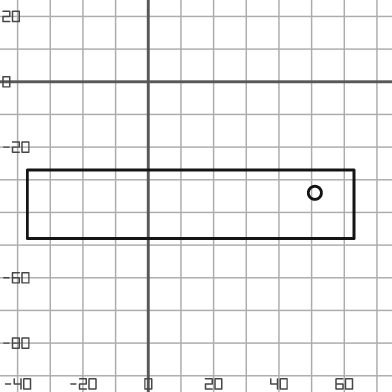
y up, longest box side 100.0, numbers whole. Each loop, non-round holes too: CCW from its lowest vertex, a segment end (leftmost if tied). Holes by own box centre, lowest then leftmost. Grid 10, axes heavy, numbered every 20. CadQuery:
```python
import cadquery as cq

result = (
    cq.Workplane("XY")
    .moveTo(-37.0, -48.0)
    .lineTo(63.0, -48.0)
    .lineTo(63.0, -27.0)
    .lineTo(-37.0, -27.0)
    .close()
    .moveTo(51.0, -34.0)
    .circle(2.0)
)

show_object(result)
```